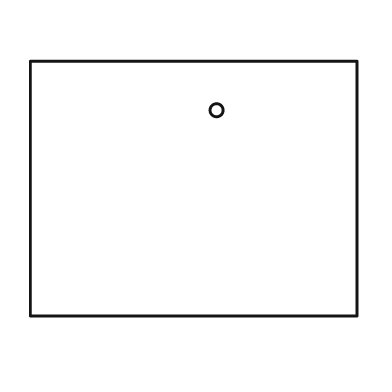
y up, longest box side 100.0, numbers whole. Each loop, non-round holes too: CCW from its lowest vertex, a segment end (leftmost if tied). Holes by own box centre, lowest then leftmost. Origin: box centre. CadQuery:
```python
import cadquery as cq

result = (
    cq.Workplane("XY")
    .moveTo(-50.0, -39.0)
    .lineTo(50.0, -39.0)
    .lineTo(50.0, 39.0)
    .lineTo(-50.0, 39.0)
    .close()
    .moveTo(7.0, 24.0)
    .circle(2.0)
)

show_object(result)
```